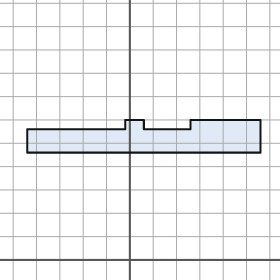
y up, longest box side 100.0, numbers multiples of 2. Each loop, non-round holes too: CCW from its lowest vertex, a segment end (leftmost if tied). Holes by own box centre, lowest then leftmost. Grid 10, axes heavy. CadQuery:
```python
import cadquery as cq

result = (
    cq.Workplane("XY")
    .moveTo(-44.0, 46.0)
    .lineTo(56.0, 46.0)
    .lineTo(56.0, 60.0)
    .lineTo(26.0, 60.0)
    .lineTo(26.0, 56.0)
    .lineTo(6.0, 56.0)
    .lineTo(6.0, 60.0)
    .lineTo(-2.0, 60.0)
    .lineTo(-2.0, 56.0)
    .lineTo(-44.0, 56.0)
    .close()
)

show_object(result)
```